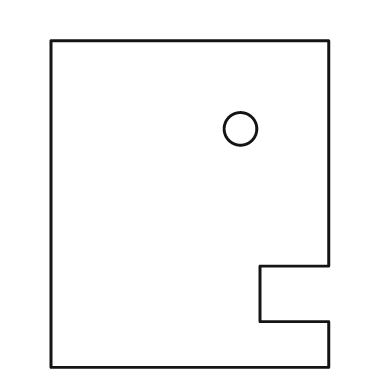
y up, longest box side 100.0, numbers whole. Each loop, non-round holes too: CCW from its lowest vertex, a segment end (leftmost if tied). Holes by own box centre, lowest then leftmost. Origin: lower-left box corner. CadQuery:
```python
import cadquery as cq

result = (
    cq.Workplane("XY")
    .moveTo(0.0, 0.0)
    .lineTo(85.0, 0.0)
    .lineTo(85.0, 14.0)
    .lineTo(64.0, 14.0)
    .lineTo(64.0, 31.0)
    .lineTo(85.0, 31.0)
    .lineTo(85.0, 100.0)
    .lineTo(0.0, 100.0)
    .close()
    .moveTo(58.0, 73.0)
    .circle(5.0)
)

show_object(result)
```